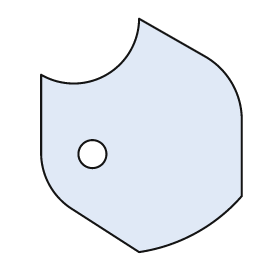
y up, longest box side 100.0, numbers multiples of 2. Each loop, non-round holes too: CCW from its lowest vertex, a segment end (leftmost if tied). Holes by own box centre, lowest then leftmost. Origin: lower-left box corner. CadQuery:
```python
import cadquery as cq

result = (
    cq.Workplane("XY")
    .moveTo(42.0, 0.0)
    .threePointArc((66.0, 8.0), (86.0, 24.0))
    .lineTo(86.0, 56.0)
    .threePointArc((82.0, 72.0), (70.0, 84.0))
    .lineTo(42.0, 100.0)
    .threePointArc((28.0, 76.0), (0.0, 76.0))
    .lineTo(0.0, 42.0)
    .threePointArc((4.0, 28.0), (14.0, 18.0))
    .close()
    .moveTo(22.0, 42.0)
    .circle(6.0)
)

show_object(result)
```